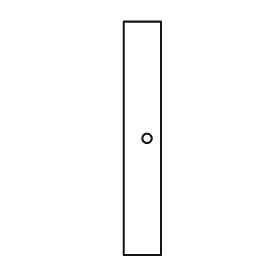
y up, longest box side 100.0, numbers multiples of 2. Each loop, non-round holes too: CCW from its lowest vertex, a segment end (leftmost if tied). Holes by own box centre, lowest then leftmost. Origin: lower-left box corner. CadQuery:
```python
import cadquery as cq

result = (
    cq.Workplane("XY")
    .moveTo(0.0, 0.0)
    .lineTo(16.0, 0.0)
    .lineTo(16.0, 100.0)
    .lineTo(0.0, 100.0)
    .close()
    .moveTo(10.0, 50.0)
    .circle(2.0)
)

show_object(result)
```